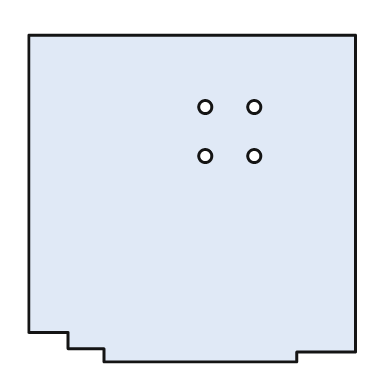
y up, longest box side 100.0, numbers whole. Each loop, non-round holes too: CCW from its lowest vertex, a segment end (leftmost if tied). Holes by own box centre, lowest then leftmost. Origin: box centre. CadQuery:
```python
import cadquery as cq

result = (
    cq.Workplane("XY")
    .moveTo(-27.0, -50.0)
    .lineTo(32.0, -50.0)
    .lineTo(32.0, -47.0)
    .lineTo(50.0, -47.0)
    .lineTo(50.0, 50.0)
    .lineTo(-50.0, 50.0)
    .lineTo(-50.0, -41.0)
    .lineTo(-38.0, -41.0)
    .lineTo(-38.0, -46.0)
    .lineTo(-27.0, -46.0)
    .close()
    .moveTo(4.0, 13.0)
    .circle(2.0)
    .moveTo(19.0, 13.0)
    .circle(2.0)
    .moveTo(4.0, 28.0)
    .circle(2.0)
    .moveTo(19.0, 28.0)
    .circle(2.0)
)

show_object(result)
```